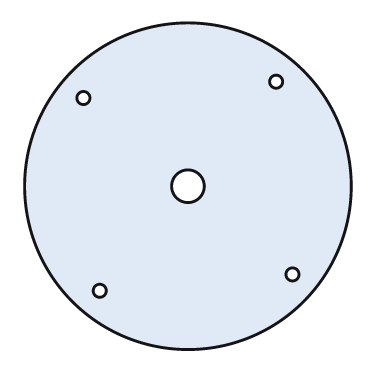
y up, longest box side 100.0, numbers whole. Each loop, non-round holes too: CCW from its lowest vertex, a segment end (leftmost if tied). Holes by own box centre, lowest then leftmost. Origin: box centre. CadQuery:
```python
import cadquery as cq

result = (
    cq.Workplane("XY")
    .moveTo(0.0, 0.0)
    .circle(50.0)
    .moveTo(-27.0, -32.0)
    .circle(2.0)
    .moveTo(32.0, -27.0)
    .circle(2.0)
    .moveTo(0.0, 0.0)
    .circle(5.0)
    .moveTo(-32.0, 27.0)
    .circle(2.0)
    .moveTo(27.0, 32.0)
    .circle(2.0)
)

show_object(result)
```